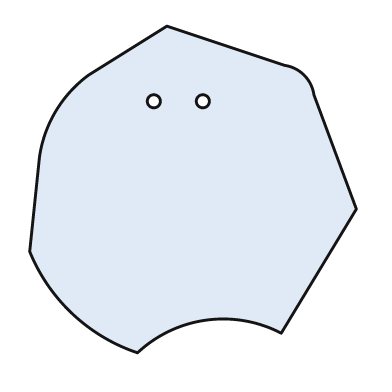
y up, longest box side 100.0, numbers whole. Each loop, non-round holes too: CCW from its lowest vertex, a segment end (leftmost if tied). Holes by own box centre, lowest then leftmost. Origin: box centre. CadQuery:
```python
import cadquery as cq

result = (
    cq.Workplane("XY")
    .moveTo(-17.0, -50.0)
    .threePointArc((4.0, -40.0), (27.0, -44.0))
    .lineTo(50.0, -6.0)
    .lineTo(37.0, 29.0)
    .threePointArc((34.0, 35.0), (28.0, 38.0))
    .lineTo(-8.0, 50.0)
    .lineTo(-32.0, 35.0)
    .threePointArc((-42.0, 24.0), (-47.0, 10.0))
    .lineTo(-50.0, -19.0)
    .threePointArc((-37.0, -38.0), (-17.0, -50.0))
    .close()
    .moveTo(-12.0, 27.0)
    .circle(2.0)
    .moveTo(3.0, 27.0)
    .circle(2.0)
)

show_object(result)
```